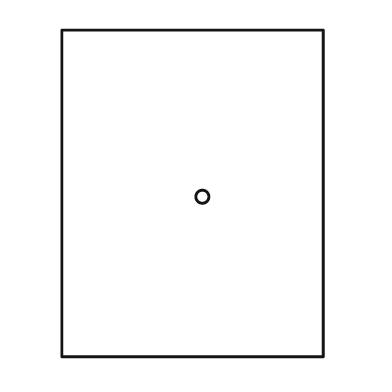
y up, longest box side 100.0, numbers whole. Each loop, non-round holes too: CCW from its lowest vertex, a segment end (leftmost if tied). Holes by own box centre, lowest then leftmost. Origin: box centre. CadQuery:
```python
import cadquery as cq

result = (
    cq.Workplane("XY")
    .moveTo(-40.0, -50.0)
    .lineTo(40.0, -50.0)
    .lineTo(40.0, 50.0)
    .lineTo(-40.0, 50.0)
    .close()
    .moveTo(3.0, -1.0)
    .circle(2.0)
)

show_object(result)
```